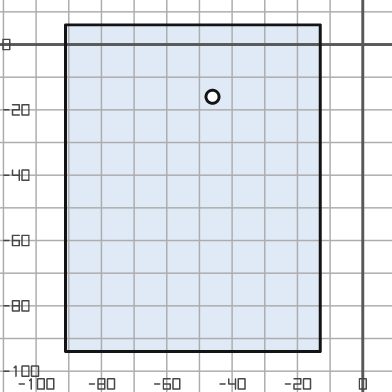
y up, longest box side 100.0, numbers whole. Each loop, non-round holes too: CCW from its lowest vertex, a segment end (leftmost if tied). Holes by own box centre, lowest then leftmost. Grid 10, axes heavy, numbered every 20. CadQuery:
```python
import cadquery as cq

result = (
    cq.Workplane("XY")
    .moveTo(-91.0, -94.0)
    .lineTo(-13.0, -94.0)
    .lineTo(-13.0, 6.0)
    .lineTo(-91.0, 6.0)
    .close()
    .moveTo(-46.0, -16.0)
    .circle(2.0)
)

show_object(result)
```